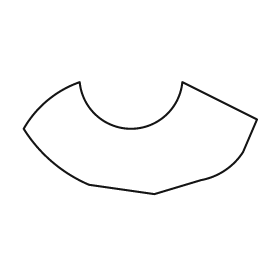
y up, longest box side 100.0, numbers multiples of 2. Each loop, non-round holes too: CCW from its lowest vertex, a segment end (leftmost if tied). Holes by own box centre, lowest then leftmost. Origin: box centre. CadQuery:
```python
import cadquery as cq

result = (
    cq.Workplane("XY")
    .moveTo(6.0, -24.0)
    .lineTo(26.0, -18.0)
    .threePointArc((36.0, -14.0), (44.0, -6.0))
    .lineTo(50.0, 8.0)
    .lineTo(18.0, 24.0)
    .threePointArc((-4.0, 4.0), (-26.0, 24.0))
    .threePointArc((-40.0, 16.0), (-50.0, 4.0))
    .threePointArc((-38.0, -10.0), (-22.0, -20.0))
    .close()
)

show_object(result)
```